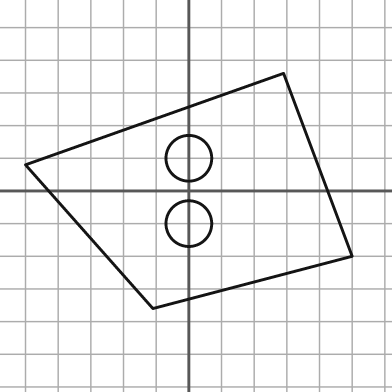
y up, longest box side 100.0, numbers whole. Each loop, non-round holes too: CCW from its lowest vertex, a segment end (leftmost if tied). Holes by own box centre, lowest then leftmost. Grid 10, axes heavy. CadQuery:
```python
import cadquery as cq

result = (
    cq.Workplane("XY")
    .moveTo(-11.0, -36.0)
    .lineTo(50.0, -20.0)
    .lineTo(29.0, 36.0)
    .lineTo(-50.0, 8.0)
    .close()
    .moveTo(0.0, -10.0)
    .circle(7.0)
    .moveTo(0.0, 10.0)
    .circle(7.0)
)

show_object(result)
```